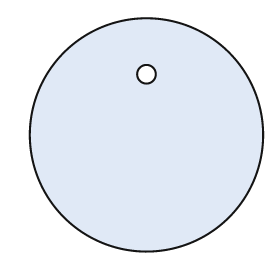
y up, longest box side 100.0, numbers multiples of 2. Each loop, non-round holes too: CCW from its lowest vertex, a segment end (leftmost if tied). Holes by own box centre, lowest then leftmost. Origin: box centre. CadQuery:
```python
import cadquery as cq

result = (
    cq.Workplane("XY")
    .moveTo(0.0, 0.0)
    .circle(50.0)
    .moveTo(0.0, 26.0)
    .circle(4.0)
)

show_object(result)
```